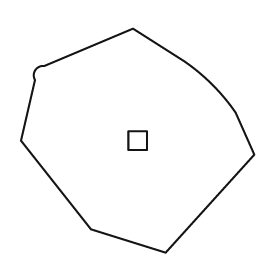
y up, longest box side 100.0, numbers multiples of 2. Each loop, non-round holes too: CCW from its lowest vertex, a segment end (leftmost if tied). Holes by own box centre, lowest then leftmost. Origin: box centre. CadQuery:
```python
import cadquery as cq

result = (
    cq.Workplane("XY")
    .moveTo(12.0, -48.0)
    .lineTo(50.0, -6.0)
    .lineTo(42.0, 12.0)
    .threePointArc((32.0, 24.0), (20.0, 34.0))
    .lineTo(-2.0, 48.0)
    .lineTo(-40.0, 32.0)
    .threePointArc((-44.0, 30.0), (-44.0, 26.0))
    .lineTo(-50.0, 0.0)
    .lineTo(-20.0, -38.0)
    .close()
    .moveTo(-4.0, -4.0)
    .lineTo(4.0, -4.0)
    .lineTo(4.0, 4.0)
    .lineTo(-4.0, 4.0)
    .close()
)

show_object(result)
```